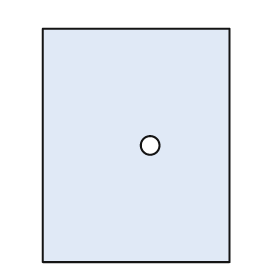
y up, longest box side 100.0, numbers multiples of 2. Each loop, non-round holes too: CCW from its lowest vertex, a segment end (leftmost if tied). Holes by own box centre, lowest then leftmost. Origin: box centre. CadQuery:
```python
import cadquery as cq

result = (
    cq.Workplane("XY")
    .moveTo(-40.0, -50.0)
    .lineTo(40.0, -50.0)
    .lineTo(40.0, 50.0)
    .lineTo(-40.0, 50.0)
    .close()
    .moveTo(6.0, 0.0)
    .circle(4.0)
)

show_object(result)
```